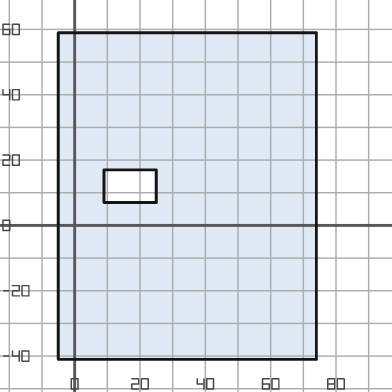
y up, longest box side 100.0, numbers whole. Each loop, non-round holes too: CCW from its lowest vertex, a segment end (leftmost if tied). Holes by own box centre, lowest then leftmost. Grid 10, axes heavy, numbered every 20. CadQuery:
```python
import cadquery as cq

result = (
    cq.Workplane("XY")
    .moveTo(-5.0, -41.0)
    .lineTo(74.0, -41.0)
    .lineTo(74.0, 59.0)
    .lineTo(-5.0, 59.0)
    .close()
    .moveTo(9.0, 7.0)
    .lineTo(25.0, 7.0)
    .lineTo(25.0, 17.0)
    .lineTo(9.0, 17.0)
    .close()
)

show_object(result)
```